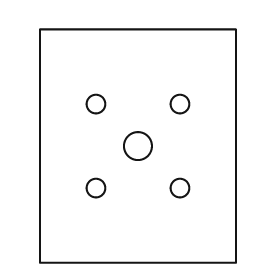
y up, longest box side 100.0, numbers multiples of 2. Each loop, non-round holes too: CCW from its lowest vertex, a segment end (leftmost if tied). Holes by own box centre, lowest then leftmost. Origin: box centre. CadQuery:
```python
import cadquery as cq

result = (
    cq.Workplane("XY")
    .moveTo(-42.0, -50.0)
    .lineTo(42.0, -50.0)
    .lineTo(42.0, 50.0)
    .lineTo(-42.0, 50.0)
    .close()
    .moveTo(-18.0, -18.0)
    .circle(4.0)
    .moveTo(18.0, -18.0)
    .circle(4.0)
    .moveTo(0.0, 0.0)
    .circle(6.0)
    .moveTo(-18.0, 18.0)
    .circle(4.0)
    .moveTo(18.0, 18.0)
    .circle(4.0)
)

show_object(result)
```